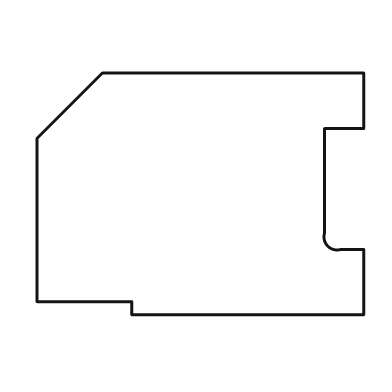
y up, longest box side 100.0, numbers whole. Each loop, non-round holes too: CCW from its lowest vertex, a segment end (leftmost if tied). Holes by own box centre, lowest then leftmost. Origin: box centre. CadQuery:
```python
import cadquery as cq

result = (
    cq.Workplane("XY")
    .moveTo(-21.0, -37.0)
    .lineTo(50.0, -37.0)
    .lineTo(50.0, -17.0)
    .lineTo(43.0, -17.0)
    .threePointArc((39.0, -16.0), (38.0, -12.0))
    .lineTo(38.0, 20.0)
    .lineTo(50.0, 20.0)
    .lineTo(50.0, 37.0)
    .lineTo(-30.0, 37.0)
    .lineTo(-50.0, 17.0)
    .lineTo(-50.0, -33.0)
    .lineTo(-21.0, -33.0)
    .close()
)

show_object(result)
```